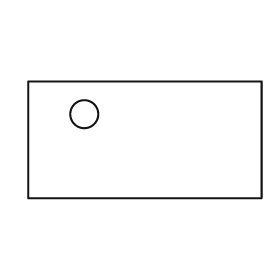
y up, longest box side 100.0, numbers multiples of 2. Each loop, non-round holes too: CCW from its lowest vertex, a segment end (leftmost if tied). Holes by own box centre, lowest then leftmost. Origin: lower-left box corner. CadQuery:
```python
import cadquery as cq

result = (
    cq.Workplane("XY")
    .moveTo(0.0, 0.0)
    .lineTo(100.0, 0.0)
    .lineTo(100.0, 50.0)
    .lineTo(0.0, 50.0)
    .close()
    .moveTo(24.0, 36.0)
    .circle(6.0)
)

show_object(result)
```